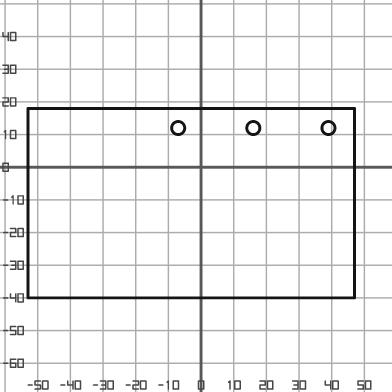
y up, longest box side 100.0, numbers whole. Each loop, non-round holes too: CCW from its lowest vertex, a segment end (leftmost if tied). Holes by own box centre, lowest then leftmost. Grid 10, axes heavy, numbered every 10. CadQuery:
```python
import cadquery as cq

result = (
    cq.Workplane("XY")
    .moveTo(-53.0, -40.0)
    .lineTo(47.0, -40.0)
    .lineTo(47.0, 18.0)
    .lineTo(-53.0, 18.0)
    .close()
    .moveTo(-7.0, 12.0)
    .circle(2.0)
    .moveTo(16.0, 12.0)
    .circle(2.0)
    .moveTo(39.0, 12.0)
    .circle(2.0)
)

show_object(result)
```